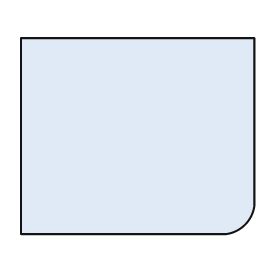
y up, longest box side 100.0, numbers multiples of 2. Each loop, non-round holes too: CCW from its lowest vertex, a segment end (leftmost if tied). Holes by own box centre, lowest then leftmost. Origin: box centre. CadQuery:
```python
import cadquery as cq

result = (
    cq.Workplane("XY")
    .moveTo(-50.0, -42.0)
    .lineTo(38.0, -42.0)
    .threePointArc((46.0, -38.0), (50.0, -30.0))
    .lineTo(50.0, 42.0)
    .lineTo(-50.0, 42.0)
    .close()
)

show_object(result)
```